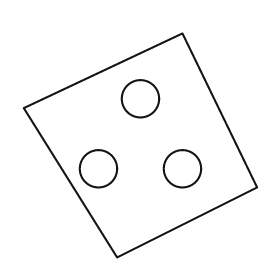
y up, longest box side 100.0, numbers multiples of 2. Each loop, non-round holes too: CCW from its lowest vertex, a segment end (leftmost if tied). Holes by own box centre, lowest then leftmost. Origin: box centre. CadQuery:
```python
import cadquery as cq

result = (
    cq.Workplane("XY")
    .moveTo(-10.0, -48.0)
    .lineTo(50.0, -18.0)
    .lineTo(18.0, 48.0)
    .lineTo(-50.0, 16.0)
    .close()
    .moveTo(-18.0, -10.0)
    .circle(8.0)
    .moveTo(18.0, -10.0)
    .circle(8.0)
    .moveTo(0.0, 20.0)
    .circle(8.0)
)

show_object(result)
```